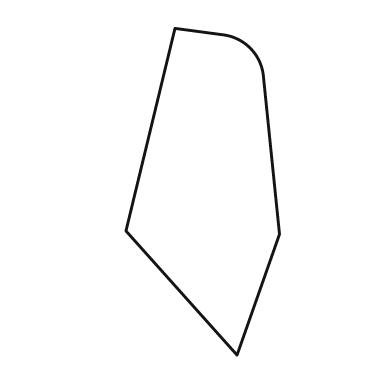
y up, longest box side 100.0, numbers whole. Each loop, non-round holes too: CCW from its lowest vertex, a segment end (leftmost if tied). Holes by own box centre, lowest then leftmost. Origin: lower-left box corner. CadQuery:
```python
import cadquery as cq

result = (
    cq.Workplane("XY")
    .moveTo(34.0, 0.0)
    .lineTo(47.0, 37.0)
    .lineTo(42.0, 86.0)
    .threePointArc((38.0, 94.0), (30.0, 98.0))
    .lineTo(15.0, 100.0)
    .lineTo(0.0, 38.0)
    .close()
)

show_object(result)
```